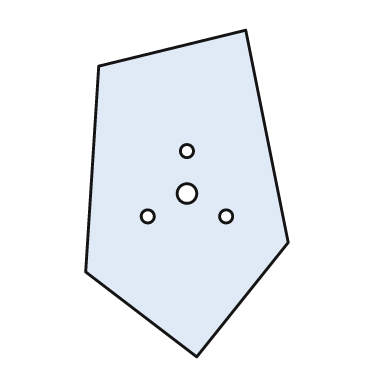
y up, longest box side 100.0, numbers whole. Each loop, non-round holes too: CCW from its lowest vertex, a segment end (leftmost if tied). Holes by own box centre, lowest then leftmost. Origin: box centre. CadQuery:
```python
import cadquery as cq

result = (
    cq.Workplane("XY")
    .moveTo(3.0, -50.0)
    .lineTo(31.0, -15.0)
    .lineTo(18.0, 50.0)
    .lineTo(-27.0, 39.0)
    .lineTo(-31.0, -24.0)
    .close()
    .moveTo(-12.0, -7.0)
    .circle(2.0)
    .moveTo(12.0, -7.0)
    .circle(2.0)
    .moveTo(0.0, 0.0)
    .circle(3.0)
    .moveTo(0.0, 13.0)
    .circle(2.0)
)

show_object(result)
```